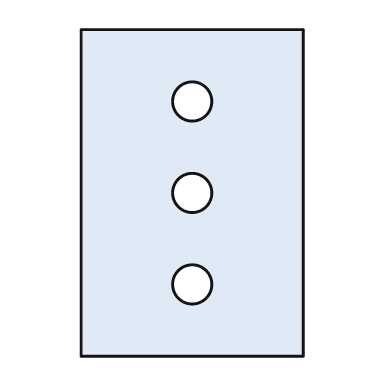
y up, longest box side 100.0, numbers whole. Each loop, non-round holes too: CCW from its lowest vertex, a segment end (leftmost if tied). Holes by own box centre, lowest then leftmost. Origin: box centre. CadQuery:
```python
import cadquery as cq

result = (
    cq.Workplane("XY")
    .moveTo(-34.0, -50.0)
    .lineTo(34.0, -50.0)
    .lineTo(34.0, 50.0)
    .lineTo(-34.0, 50.0)
    .close()
    .moveTo(0.0, -28.0)
    .circle(6.0)
    .moveTo(0.0, 0.0)
    .circle(6.0)
    .moveTo(0.0, 28.0)
    .circle(6.0)
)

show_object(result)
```